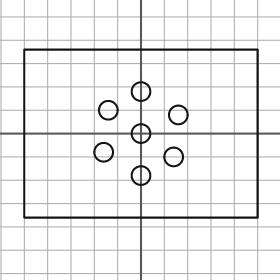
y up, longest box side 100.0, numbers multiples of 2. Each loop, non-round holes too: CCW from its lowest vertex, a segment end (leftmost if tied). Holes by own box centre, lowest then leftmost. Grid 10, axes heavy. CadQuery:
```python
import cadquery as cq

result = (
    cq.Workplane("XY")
    .moveTo(-50.0, -36.0)
    .lineTo(50.0, -36.0)
    .lineTo(50.0, 36.0)
    .lineTo(-50.0, 36.0)
    .close()
    .moveTo(0.0, -18.0)
    .circle(4.0)
    .moveTo(14.0, -10.0)
    .circle(4.0)
    .moveTo(-16.0, -8.0)
    .circle(4.0)
    .moveTo(0.0, 0.0)
    .circle(4.0)
    .moveTo(16.0, 8.0)
    .circle(4.0)
    .moveTo(-14.0, 10.0)
    .circle(4.0)
    .moveTo(0.0, 18.0)
    .circle(4.0)
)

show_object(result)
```